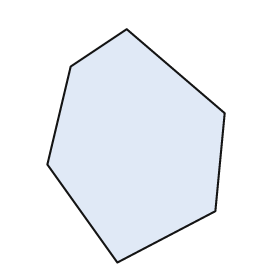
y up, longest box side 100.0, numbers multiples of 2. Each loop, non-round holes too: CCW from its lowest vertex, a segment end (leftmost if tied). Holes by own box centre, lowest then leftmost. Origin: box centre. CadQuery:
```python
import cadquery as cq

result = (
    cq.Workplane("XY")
    .moveTo(-8.0, -50.0)
    .lineTo(34.0, -28.0)
    .lineTo(38.0, 14.0)
    .lineTo(-4.0, 50.0)
    .lineTo(-28.0, 34.0)
    .lineTo(-38.0, -8.0)
    .close()
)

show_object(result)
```